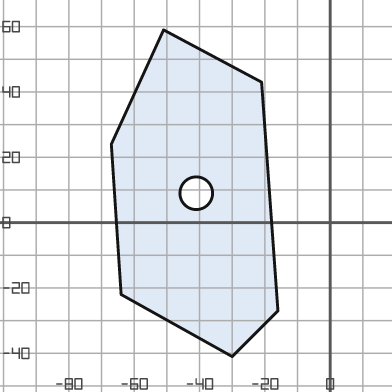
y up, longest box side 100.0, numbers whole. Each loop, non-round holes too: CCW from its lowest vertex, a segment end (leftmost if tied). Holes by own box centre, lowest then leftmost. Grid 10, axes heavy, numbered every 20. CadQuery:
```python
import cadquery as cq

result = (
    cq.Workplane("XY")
    .moveTo(-30.0, -41.0)
    .lineTo(-16.0, -27.0)
    .lineTo(-21.0, 43.0)
    .lineTo(-51.0, 59.0)
    .lineTo(-67.0, 24.0)
    .lineTo(-64.0, -22.0)
    .close()
    .moveTo(-41.0, 9.0)
    .circle(5.0)
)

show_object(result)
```